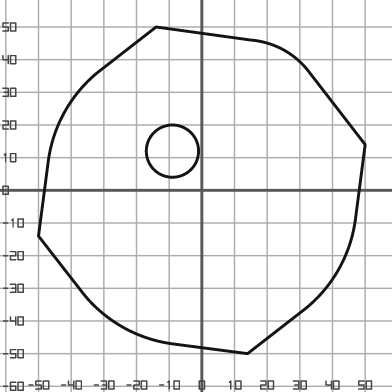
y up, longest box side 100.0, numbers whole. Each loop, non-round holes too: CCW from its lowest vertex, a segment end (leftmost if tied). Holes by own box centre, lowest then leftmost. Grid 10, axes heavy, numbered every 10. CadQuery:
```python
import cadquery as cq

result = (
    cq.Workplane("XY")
    .moveTo(14.0, -50.0)
    .lineTo(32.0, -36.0)
    .threePointArc((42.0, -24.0), (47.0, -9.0))
    .lineTo(50.0, 14.0)
    .lineTo(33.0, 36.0)
    .threePointArc((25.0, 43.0), (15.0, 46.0))
    .lineTo(-14.0, 50.0)
    .lineTo(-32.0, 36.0)
    .threePointArc((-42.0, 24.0), (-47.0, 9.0))
    .lineTo(-50.0, -14.0)
    .lineTo(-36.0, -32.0)
    .threePointArc((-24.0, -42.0), (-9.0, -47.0))
    .close()
    .moveTo(-9.0, 12.0)
    .circle(8.0)
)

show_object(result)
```